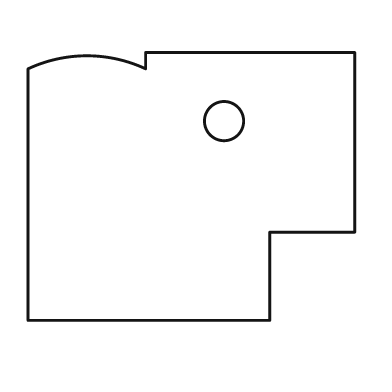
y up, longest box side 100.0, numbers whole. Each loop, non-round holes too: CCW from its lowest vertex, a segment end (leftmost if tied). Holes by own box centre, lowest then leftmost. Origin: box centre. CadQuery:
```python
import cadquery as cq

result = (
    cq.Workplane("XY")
    .moveTo(-50.0, -41.0)
    .lineTo(24.0, -41.0)
    .lineTo(24.0, -14.0)
    .lineTo(50.0, -14.0)
    .lineTo(50.0, 41.0)
    .lineTo(-14.0, 41.0)
    .lineTo(-14.0, 36.0)
    .threePointArc((-32.0, 40.0), (-50.0, 36.0))
    .close()
    .moveTo(10.0, 20.0)
    .circle(6.0)
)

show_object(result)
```